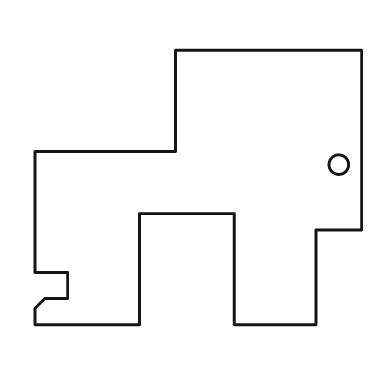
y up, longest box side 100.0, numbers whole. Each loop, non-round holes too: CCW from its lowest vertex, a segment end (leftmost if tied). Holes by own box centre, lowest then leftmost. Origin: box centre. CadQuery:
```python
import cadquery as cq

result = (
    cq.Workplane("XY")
    .moveTo(-50.0, -42.0)
    .lineTo(-18.0, -42.0)
    .lineTo(-18.0, -8.0)
    .lineTo(11.0, -8.0)
    .lineTo(11.0, -42.0)
    .lineTo(36.0, -42.0)
    .lineTo(36.0, -13.0)
    .lineTo(50.0, -13.0)
    .lineTo(50.0, 42.0)
    .lineTo(-7.0, 42.0)
    .lineTo(-7.0, 11.0)
    .lineTo(-50.0, 11.0)
    .lineTo(-50.0, -26.0)
    .lineTo(-40.0, -26.0)
    .lineTo(-40.0, -34.0)
    .lineTo(-47.0, -34.0)
    .lineTo(-50.0, -37.0)
    .close()
    .moveTo(43.0, 7.0)
    .circle(3.0)
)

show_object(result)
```